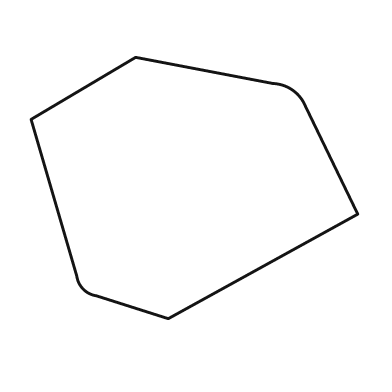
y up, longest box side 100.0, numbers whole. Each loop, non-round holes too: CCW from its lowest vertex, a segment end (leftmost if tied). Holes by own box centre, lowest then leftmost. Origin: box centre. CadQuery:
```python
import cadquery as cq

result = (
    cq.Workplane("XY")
    .moveTo(-8.0, -40.0)
    .lineTo(50.0, -8.0)
    .lineTo(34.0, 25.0)
    .threePointArc((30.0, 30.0), (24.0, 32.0))
    .lineTo(-18.0, 40.0)
    .lineTo(-50.0, 21.0)
    .lineTo(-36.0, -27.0)
    .threePointArc((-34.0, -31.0), (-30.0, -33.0))
    .close()
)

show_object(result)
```